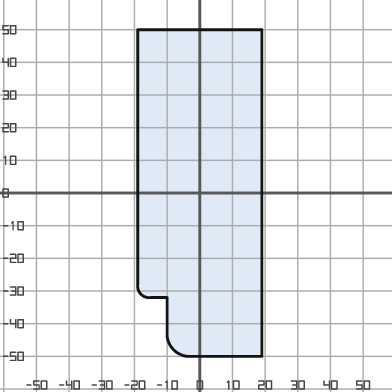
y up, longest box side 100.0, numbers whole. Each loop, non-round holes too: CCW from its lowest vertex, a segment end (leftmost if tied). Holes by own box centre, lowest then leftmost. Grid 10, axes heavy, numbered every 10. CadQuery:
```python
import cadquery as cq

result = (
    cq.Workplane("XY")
    .moveTo(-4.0, -50.0)
    .lineTo(19.0, -50.0)
    .lineTo(19.0, 50.0)
    .lineTo(-19.0, 50.0)
    .lineTo(-19.0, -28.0)
    .threePointArc((-18.0, -31.0), (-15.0, -32.0))
    .lineTo(-10.0, -32.0)
    .lineTo(-10.0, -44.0)
    .threePointArc((-8.0, -48.0), (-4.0, -50.0))
    .close()
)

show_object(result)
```